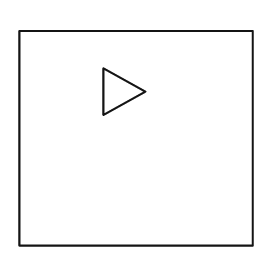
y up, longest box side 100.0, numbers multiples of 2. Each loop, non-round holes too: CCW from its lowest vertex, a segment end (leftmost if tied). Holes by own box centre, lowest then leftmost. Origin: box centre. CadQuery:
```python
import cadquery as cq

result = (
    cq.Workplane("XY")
    .moveTo(-50.0, -46.0)
    .lineTo(50.0, -46.0)
    .lineTo(50.0, 46.0)
    .lineTo(-50.0, 46.0)
    .close()
    .moveTo(-14.0, 10.0)
    .lineTo(4.0, 20.0)
    .lineTo(-14.0, 30.0)
    .close()
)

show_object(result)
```